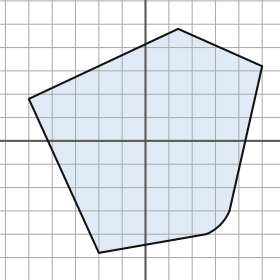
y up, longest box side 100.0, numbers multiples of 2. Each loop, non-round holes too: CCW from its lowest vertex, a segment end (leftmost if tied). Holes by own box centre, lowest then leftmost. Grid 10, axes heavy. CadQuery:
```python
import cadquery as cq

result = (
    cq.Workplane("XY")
    .moveTo(-20.0, -48.0)
    .lineTo(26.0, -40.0)
    .threePointArc((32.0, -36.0), (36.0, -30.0))
    .lineTo(50.0, 32.0)
    .lineTo(14.0, 48.0)
    .lineTo(-50.0, 18.0)
    .close()
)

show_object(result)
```